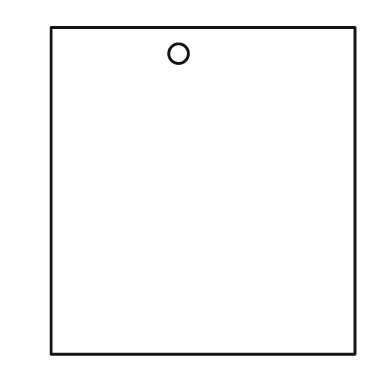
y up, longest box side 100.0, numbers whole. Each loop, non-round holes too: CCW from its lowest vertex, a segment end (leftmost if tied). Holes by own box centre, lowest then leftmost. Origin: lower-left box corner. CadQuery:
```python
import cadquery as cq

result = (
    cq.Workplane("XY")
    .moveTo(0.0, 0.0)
    .lineTo(93.0, 0.0)
    .lineTo(93.0, 100.0)
    .lineTo(0.0, 100.0)
    .close()
    .moveTo(39.0, 92.0)
    .circle(3.0)
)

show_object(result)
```